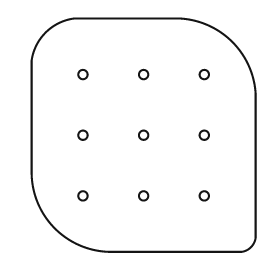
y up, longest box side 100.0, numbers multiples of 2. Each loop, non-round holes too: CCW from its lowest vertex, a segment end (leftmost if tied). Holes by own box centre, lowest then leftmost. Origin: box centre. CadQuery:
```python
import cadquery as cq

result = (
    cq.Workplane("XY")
    .moveTo(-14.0, -50.0)
    .lineTo(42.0, -50.0)
    .threePointArc((46.0, -48.0), (48.0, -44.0))
    .lineTo(48.0, 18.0)
    .threePointArc((38.0, 40.0), (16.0, 50.0))
    .lineTo(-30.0, 50.0)
    .threePointArc((-42.0, 44.0), (-48.0, 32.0))
    .lineTo(-48.0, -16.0)
    .threePointArc((-38.0, -40.0), (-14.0, -50.0))
    .close()
    .moveTo(-26.0, -26.0)
    .circle(2.0)
    .moveTo(0.0, -26.0)
    .circle(2.0)
    .moveTo(26.0, -26.0)
    .circle(2.0)
    .moveTo(-26.0, 0.0)
    .circle(2.0)
    .moveTo(0.0, 0.0)
    .circle(2.0)
    .moveTo(26.0, 0.0)
    .circle(2.0)
    .moveTo(-26.0, 26.0)
    .circle(2.0)
    .moveTo(0.0, 26.0)
    .circle(2.0)
    .moveTo(26.0, 26.0)
    .circle(2.0)
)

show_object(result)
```